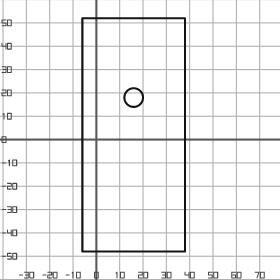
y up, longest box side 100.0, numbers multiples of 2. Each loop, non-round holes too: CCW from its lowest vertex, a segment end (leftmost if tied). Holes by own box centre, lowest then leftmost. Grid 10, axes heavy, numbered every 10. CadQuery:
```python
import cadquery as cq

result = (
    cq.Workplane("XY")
    .moveTo(-6.0, -48.0)
    .lineTo(38.0, -48.0)
    .lineTo(38.0, 52.0)
    .lineTo(-6.0, 52.0)
    .close()
    .moveTo(16.0, 18.0)
    .circle(4.0)
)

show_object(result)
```